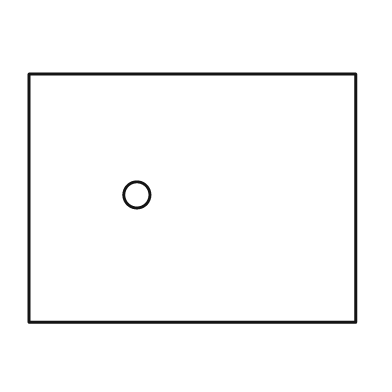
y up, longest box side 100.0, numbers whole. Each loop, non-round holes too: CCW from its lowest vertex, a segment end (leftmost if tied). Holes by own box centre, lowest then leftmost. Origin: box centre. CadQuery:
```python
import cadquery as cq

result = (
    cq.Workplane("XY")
    .moveTo(-50.0, -38.0)
    .lineTo(50.0, -38.0)
    .lineTo(50.0, 38.0)
    .lineTo(-50.0, 38.0)
    .close()
    .moveTo(-17.0, 1.0)
    .circle(4.0)
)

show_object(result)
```